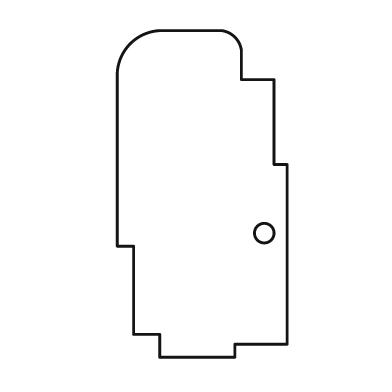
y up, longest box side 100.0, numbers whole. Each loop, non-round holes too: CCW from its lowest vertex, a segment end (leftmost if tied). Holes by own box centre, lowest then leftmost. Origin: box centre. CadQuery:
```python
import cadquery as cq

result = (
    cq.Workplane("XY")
    .moveTo(-13.0, -50.0)
    .lineTo(10.0, -50.0)
    .lineTo(10.0, -46.0)
    .lineTo(26.0, -46.0)
    .lineTo(26.0, 9.0)
    .lineTo(22.0, 9.0)
    .lineTo(22.0, 35.0)
    .lineTo(12.0, 35.0)
    .lineTo(12.0, 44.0)
    .threePointArc((10.0, 48.0), (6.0, 50.0))
    .lineTo(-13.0, 50.0)
    .threePointArc((-22.0, 46.0), (-26.0, 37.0))
    .lineTo(-26.0, -16.0)
    .lineTo(-21.0, -16.0)
    .lineTo(-21.0, -43.0)
    .lineTo(-13.0, -43.0)
    .close()
    .moveTo(19.0, -12.0)
    .circle(3.0)
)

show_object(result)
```